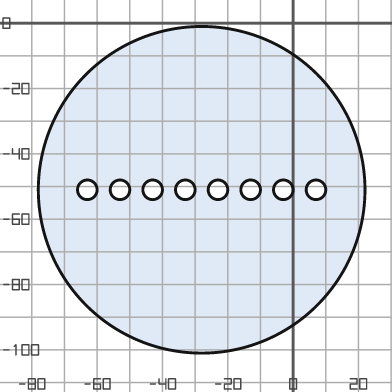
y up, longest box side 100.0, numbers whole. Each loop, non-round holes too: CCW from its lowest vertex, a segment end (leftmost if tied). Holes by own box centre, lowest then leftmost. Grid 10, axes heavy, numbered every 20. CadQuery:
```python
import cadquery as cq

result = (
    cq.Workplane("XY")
    .moveTo(-28.0, -51.0)
    .circle(50.0)
    .moveTo(-63.0, -51.0)
    .circle(3.0)
    .moveTo(-53.0, -51.0)
    .circle(3.0)
    .moveTo(-43.0, -51.0)
    .circle(3.0)
    .moveTo(-33.0, -51.0)
    .circle(3.0)
    .moveTo(-23.0, -51.0)
    .circle(3.0)
    .moveTo(-13.0, -51.0)
    .circle(3.0)
    .moveTo(-3.0, -51.0)
    .circle(3.0)
    .moveTo(7.0, -51.0)
    .circle(3.0)
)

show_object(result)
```